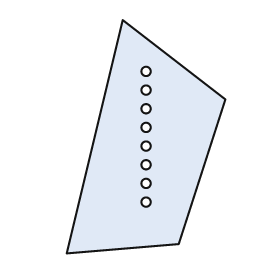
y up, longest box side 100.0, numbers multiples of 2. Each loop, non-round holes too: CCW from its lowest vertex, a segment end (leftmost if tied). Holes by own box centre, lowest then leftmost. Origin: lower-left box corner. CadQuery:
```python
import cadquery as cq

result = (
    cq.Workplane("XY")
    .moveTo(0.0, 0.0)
    .lineTo(48.0, 4.0)
    .lineTo(68.0, 66.0)
    .lineTo(24.0, 100.0)
    .close()
    .moveTo(34.0, 22.0)
    .circle(2.0)
    .moveTo(34.0, 30.0)
    .circle(2.0)
    .moveTo(34.0, 38.0)
    .circle(2.0)
    .moveTo(34.0, 46.0)
    .circle(2.0)
    .moveTo(34.0, 54.0)
    .circle(2.0)
    .moveTo(34.0, 62.0)
    .circle(2.0)
    .moveTo(34.0, 70.0)
    .circle(2.0)
    .moveTo(34.0, 78.0)
    .circle(2.0)
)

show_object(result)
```